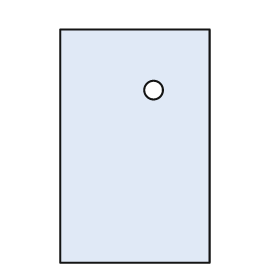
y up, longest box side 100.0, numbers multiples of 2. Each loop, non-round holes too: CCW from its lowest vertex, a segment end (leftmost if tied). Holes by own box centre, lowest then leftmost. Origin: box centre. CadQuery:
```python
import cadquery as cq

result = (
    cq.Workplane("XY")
    .moveTo(-32.0, -50.0)
    .lineTo(32.0, -50.0)
    .lineTo(32.0, 50.0)
    .lineTo(-32.0, 50.0)
    .close()
    .moveTo(8.0, 24.0)
    .circle(4.0)
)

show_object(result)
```